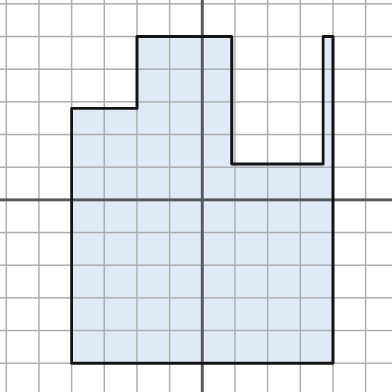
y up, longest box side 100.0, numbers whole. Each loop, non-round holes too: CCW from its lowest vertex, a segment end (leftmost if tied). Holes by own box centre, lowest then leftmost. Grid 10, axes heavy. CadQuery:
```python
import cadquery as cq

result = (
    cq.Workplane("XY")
    .moveTo(-40.0, -50.0)
    .lineTo(40.0, -50.0)
    .lineTo(40.0, 50.0)
    .lineTo(37.0, 50.0)
    .lineTo(37.0, 11.0)
    .lineTo(9.0, 11.0)
    .lineTo(9.0, 50.0)
    .lineTo(-20.0, 50.0)
    .lineTo(-20.0, 28.0)
    .lineTo(-40.0, 28.0)
    .close()
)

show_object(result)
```